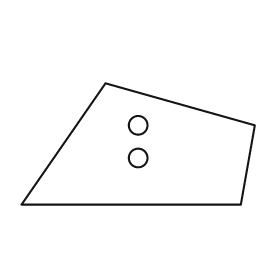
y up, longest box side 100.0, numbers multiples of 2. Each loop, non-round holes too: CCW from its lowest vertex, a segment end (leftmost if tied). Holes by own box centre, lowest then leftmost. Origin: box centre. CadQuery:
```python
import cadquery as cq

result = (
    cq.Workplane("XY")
    .moveTo(-50.0, -26.0)
    .lineTo(44.0, -26.0)
    .lineTo(50.0, 8.0)
    .lineTo(-14.0, 26.0)
    .close()
    .moveTo(0.0, -6.0)
    .circle(4.0)
    .moveTo(0.0, 8.0)
    .circle(4.0)
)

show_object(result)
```